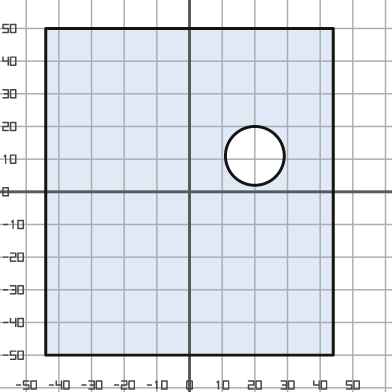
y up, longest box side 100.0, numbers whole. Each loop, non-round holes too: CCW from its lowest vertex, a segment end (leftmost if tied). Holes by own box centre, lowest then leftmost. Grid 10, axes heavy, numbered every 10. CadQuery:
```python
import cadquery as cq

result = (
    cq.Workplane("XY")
    .moveTo(-44.0, -50.0)
    .lineTo(44.0, -50.0)
    .lineTo(44.0, 50.0)
    .lineTo(-44.0, 50.0)
    .close()
    .moveTo(20.0, 11.0)
    .circle(9.0)
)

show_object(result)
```